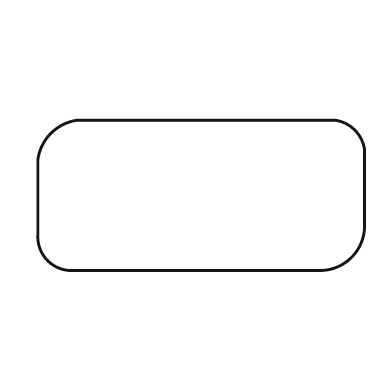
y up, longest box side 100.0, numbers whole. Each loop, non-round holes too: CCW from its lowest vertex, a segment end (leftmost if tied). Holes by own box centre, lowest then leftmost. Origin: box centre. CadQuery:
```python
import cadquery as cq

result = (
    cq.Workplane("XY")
    .moveTo(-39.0, -23.0)
    .lineTo(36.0, -23.0)
    .threePointArc((46.0, -19.0), (50.0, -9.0))
    .lineTo(50.0, 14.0)
    .threePointArc((47.0, 20.0), (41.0, 23.0))
    .lineTo(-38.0, 23.0)
    .threePointArc((-46.0, 19.0), (-50.0, 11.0))
    .lineTo(-50.0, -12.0)
    .threePointArc((-47.0, -20.0), (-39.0, -23.0))
    .close()
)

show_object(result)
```